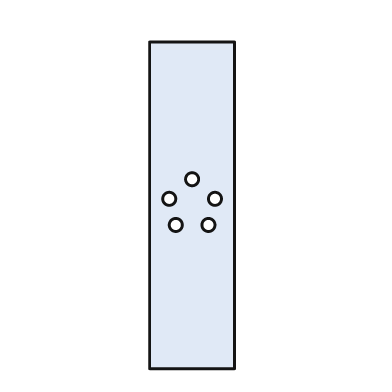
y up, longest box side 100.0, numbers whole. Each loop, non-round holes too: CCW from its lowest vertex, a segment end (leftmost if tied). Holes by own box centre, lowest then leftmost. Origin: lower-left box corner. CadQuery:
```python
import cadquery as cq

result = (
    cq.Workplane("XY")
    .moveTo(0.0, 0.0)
    .lineTo(26.0, 0.0)
    .lineTo(26.0, 100.0)
    .lineTo(0.0, 100.0)
    .close()
    .moveTo(8.0, 44.0)
    .circle(2.0)
    .moveTo(18.0, 44.0)
    .circle(2.0)
    .moveTo(6.0, 52.0)
    .circle(2.0)
    .moveTo(20.0, 52.0)
    .circle(2.0)
    .moveTo(13.0, 58.0)
    .circle(2.0)
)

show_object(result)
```